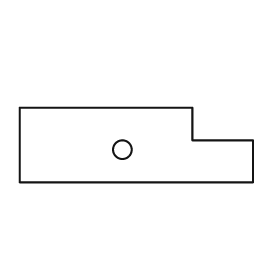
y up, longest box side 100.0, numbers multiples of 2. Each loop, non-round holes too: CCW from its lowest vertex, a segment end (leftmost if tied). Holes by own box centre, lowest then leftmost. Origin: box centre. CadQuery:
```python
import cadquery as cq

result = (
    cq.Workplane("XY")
    .moveTo(-50.0, -16.0)
    .lineTo(50.0, -16.0)
    .lineTo(50.0, 2.0)
    .lineTo(24.0, 2.0)
    .lineTo(24.0, 16.0)
    .lineTo(-50.0, 16.0)
    .close()
    .moveTo(-6.0, -2.0)
    .circle(4.0)
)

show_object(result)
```